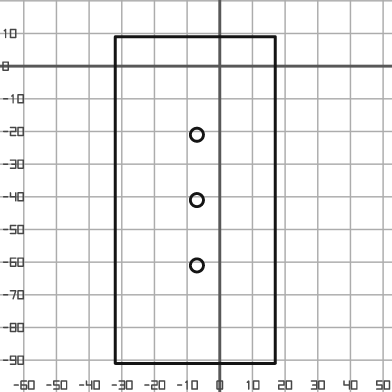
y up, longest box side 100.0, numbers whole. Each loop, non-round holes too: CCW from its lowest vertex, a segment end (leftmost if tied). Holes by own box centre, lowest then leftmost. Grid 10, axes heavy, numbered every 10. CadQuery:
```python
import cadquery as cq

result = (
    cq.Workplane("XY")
    .moveTo(-32.0, -91.0)
    .lineTo(17.0, -91.0)
    .lineTo(17.0, 9.0)
    .lineTo(-32.0, 9.0)
    .close()
    .moveTo(-7.0, -61.0)
    .circle(2.0)
    .moveTo(-7.0, -41.0)
    .circle(2.0)
    .moveTo(-7.0, -21.0)
    .circle(2.0)
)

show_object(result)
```